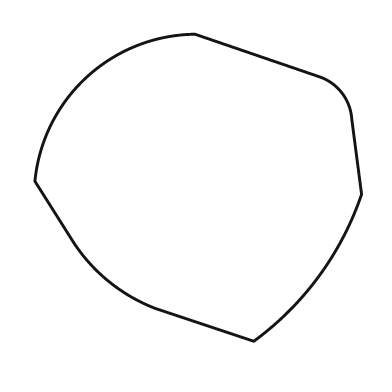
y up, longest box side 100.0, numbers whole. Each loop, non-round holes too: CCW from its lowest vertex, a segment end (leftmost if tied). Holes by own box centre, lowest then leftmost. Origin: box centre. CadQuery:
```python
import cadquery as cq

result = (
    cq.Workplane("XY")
    .moveTo(17.0, -47.0)
    .threePointArc((37.0, -27.0), (50.0, -2.0))
    .lineTo(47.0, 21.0)
    .threePointArc((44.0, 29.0), (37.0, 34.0))
    .lineTo(-1.0, 47.0)
    .threePointArc((-34.0, 34.0), (-50.0, 2.0))
    .lineTo(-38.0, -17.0)
    .threePointArc((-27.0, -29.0), (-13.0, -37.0))
    .close()
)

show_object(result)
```